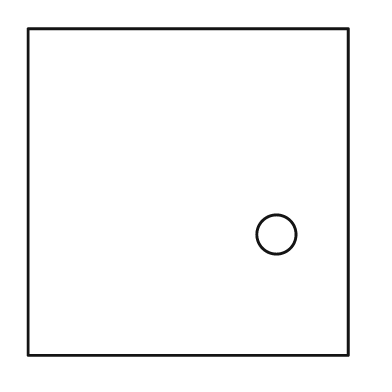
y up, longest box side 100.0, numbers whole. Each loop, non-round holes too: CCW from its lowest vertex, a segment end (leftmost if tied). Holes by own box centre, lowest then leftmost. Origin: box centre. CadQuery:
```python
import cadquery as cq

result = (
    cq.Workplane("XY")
    .moveTo(-49.0, -50.0)
    .lineTo(49.0, -50.0)
    .lineTo(49.0, 50.0)
    .lineTo(-49.0, 50.0)
    .close()
    .moveTo(27.0, -13.0)
    .circle(6.0)
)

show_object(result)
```